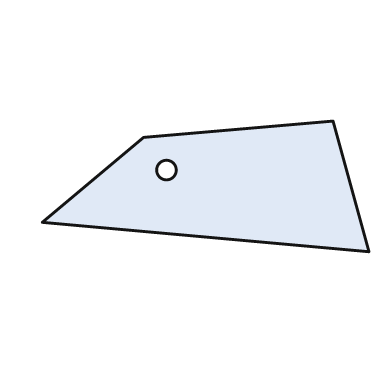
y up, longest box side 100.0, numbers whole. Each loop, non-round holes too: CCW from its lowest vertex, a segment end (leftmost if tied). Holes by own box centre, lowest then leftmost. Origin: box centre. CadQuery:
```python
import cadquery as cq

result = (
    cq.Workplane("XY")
    .moveTo(50.0, -20.0)
    .lineTo(39.0, 20.0)
    .lineTo(-19.0, 15.0)
    .lineTo(-50.0, -11.0)
    .close()
    .moveTo(-12.0, 5.0)
    .circle(3.0)
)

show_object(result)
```